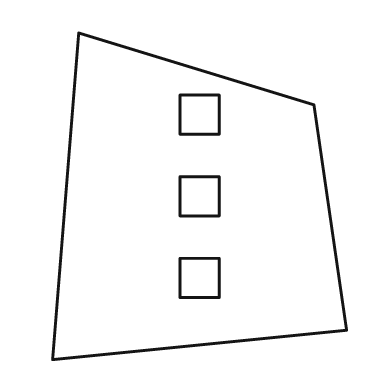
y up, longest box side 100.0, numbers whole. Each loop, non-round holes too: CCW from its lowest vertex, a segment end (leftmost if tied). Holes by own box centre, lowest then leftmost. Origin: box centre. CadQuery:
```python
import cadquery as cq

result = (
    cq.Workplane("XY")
    .moveTo(-45.0, -50.0)
    .lineTo(45.0, -41.0)
    .lineTo(35.0, 28.0)
    .lineTo(-37.0, 50.0)
    .close()
    .moveTo(-6.0, -31.0)
    .lineTo(6.0, -31.0)
    .lineTo(6.0, -19.0)
    .lineTo(-6.0, -19.0)
    .close()
    .moveTo(-6.0, -6.0)
    .lineTo(6.0, -6.0)
    .lineTo(6.0, 6.0)
    .lineTo(-6.0, 6.0)
    .close()
    .moveTo(-6.0, 19.0)
    .lineTo(6.0, 19.0)
    .lineTo(6.0, 31.0)
    .lineTo(-6.0, 31.0)
    .close()
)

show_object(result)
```